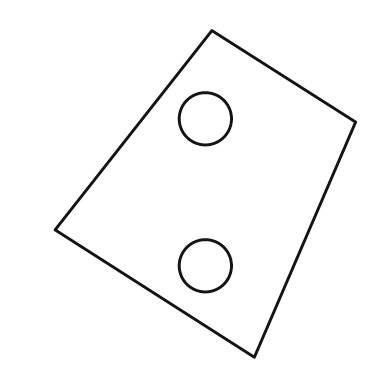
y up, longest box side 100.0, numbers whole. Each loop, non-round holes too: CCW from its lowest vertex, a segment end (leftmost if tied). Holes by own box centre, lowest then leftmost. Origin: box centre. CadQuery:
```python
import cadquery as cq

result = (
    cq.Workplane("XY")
    .moveTo(15.0, -50.0)
    .lineTo(46.0, 22.0)
    .lineTo(2.0, 50.0)
    .lineTo(-46.0, -11.0)
    .close()
    .moveTo(0.0, -22.0)
    .circle(8.0)
    .moveTo(0.0, 23.0)
    .circle(8.0)
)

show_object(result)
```